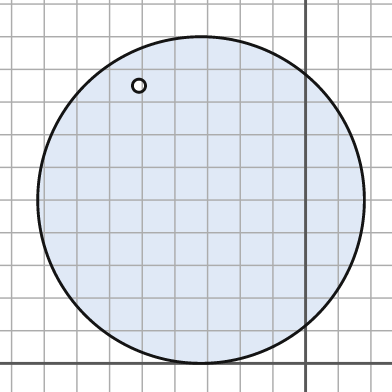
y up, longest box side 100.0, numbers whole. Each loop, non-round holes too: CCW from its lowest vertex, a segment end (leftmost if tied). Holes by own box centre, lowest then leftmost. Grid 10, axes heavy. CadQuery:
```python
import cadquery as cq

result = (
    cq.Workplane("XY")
    .moveTo(-32.0, 50.0)
    .circle(50.0)
    .moveTo(-51.0, 85.0)
    .circle(2.0)
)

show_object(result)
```